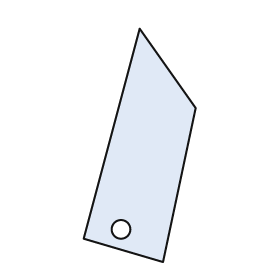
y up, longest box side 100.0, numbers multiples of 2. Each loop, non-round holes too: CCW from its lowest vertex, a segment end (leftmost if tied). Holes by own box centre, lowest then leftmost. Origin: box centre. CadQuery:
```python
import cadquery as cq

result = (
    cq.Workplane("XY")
    .moveTo(10.0, -50.0)
    .lineTo(24.0, 16.0)
    .lineTo(0.0, 50.0)
    .lineTo(-24.0, -40.0)
    .close()
    .moveTo(-8.0, -36.0)
    .circle(4.0)
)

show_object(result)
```